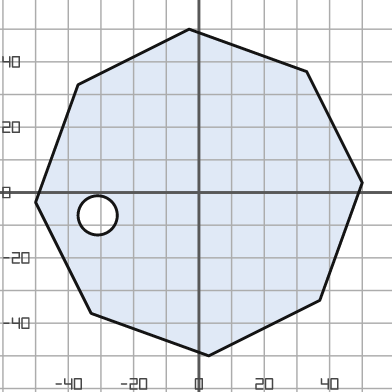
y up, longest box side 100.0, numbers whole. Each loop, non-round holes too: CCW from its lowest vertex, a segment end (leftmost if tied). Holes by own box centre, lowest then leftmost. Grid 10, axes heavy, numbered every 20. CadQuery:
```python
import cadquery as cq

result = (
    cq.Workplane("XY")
    .moveTo(3.0, -50.0)
    .lineTo(37.0, -33.0)
    .lineTo(50.0, 3.0)
    .lineTo(33.0, 37.0)
    .lineTo(-3.0, 50.0)
    .lineTo(-37.0, 33.0)
    .lineTo(-50.0, -3.0)
    .lineTo(-33.0, -37.0)
    .close()
    .moveTo(-31.0, -7.0)
    .circle(6.0)
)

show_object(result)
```